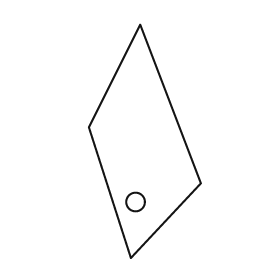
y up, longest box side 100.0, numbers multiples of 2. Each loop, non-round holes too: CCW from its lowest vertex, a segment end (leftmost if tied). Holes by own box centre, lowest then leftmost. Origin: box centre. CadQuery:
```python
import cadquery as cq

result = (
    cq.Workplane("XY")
    .moveTo(-6.0, -50.0)
    .lineTo(24.0, -18.0)
    .lineTo(-2.0, 50.0)
    .lineTo(-24.0, 6.0)
    .close()
    .moveTo(-4.0, -26.0)
    .circle(4.0)
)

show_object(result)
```